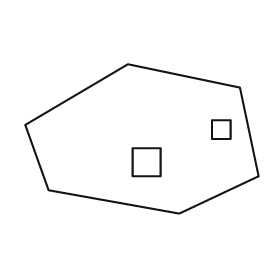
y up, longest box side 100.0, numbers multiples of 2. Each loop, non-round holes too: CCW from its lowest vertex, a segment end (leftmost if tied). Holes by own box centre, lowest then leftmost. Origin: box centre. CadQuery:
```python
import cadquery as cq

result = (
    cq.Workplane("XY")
    .moveTo(16.0, -32.0)
    .lineTo(50.0, -16.0)
    .lineTo(42.0, 22.0)
    .lineTo(-6.0, 32.0)
    .lineTo(-50.0, 6.0)
    .lineTo(-40.0, -22.0)
    .close()
    .moveTo(-4.0, -16.0)
    .lineTo(8.0, -16.0)
    .lineTo(8.0, -4.0)
    .lineTo(-4.0, -4.0)
    .close()
    .moveTo(30.0, 0.0)
    .lineTo(38.0, 0.0)
    .lineTo(38.0, 8.0)
    .lineTo(30.0, 8.0)
    .close()
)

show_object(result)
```